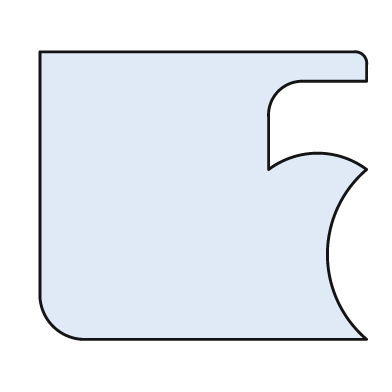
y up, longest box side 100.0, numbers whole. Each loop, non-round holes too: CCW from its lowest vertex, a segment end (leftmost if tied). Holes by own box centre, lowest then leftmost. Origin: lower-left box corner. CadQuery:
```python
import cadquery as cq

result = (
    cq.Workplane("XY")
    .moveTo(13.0, 0.0)
    .lineTo(100.0, 0.0)
    .threePointArc((88.0, 26.0), (100.0, 52.0))
    .threePointArc((85.0, 57.0), (70.0, 52.0))
    .lineTo(70.0, 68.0)
    .threePointArc((73.0, 76.0), (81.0, 79.0))
    .lineTo(100.0, 79.0)
    .lineTo(100.0, 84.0)
    .threePointArc((99.0, 87.0), (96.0, 88.0))
    .lineTo(0.0, 88.0)
    .lineTo(0.0, 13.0)
    .threePointArc((4.0, 4.0), (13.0, 0.0))
    .close()
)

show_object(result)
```